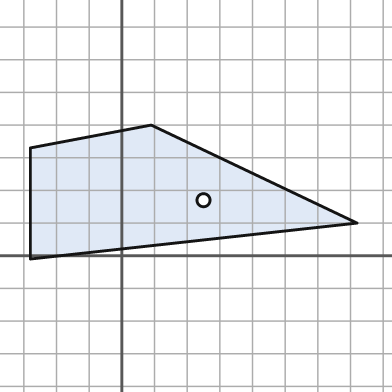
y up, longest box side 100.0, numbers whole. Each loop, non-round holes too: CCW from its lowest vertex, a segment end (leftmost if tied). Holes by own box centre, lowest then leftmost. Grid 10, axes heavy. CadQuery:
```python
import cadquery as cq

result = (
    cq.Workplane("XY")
    .moveTo(-28.0, -1.0)
    .lineTo(72.0, 10.0)
    .lineTo(9.0, 40.0)
    .lineTo(-28.0, 33.0)
    .close()
    .moveTo(25.0, 17.0)
    .circle(2.0)
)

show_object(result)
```